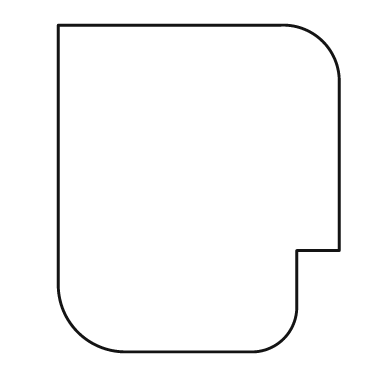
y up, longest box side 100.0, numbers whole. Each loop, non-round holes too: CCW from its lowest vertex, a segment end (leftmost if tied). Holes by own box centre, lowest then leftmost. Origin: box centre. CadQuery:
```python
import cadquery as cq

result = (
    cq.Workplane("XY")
    .moveTo(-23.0, -50.0)
    .lineTo(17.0, -50.0)
    .threePointArc((26.0, -46.0), (30.0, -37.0))
    .lineTo(30.0, -19.0)
    .lineTo(43.0, -19.0)
    .lineTo(43.0, 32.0)
    .threePointArc((38.0, 45.0), (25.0, 50.0))
    .lineTo(-43.0, 50.0)
    .lineTo(-43.0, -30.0)
    .threePointArc((-37.0, -44.0), (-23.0, -50.0))
    .close()
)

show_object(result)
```